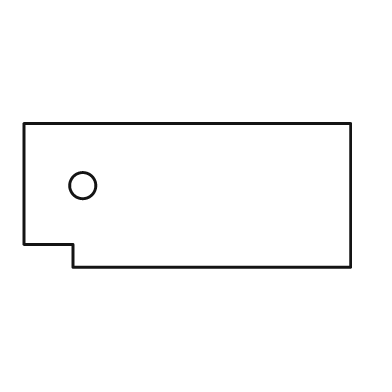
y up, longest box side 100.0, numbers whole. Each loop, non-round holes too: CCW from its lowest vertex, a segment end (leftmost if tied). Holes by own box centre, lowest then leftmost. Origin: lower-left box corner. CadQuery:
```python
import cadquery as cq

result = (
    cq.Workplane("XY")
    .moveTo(15.0, 0.0)
    .lineTo(100.0, 0.0)
    .lineTo(100.0, 44.0)
    .lineTo(0.0, 44.0)
    .lineTo(0.0, 7.0)
    .lineTo(15.0, 7.0)
    .close()
    .moveTo(18.0, 25.0)
    .circle(4.0)
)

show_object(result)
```